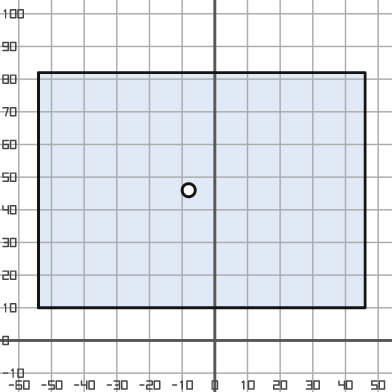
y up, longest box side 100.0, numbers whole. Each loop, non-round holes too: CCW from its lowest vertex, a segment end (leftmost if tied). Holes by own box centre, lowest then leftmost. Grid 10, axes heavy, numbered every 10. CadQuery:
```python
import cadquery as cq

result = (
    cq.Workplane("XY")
    .moveTo(-54.0, 10.0)
    .lineTo(46.0, 10.0)
    .lineTo(46.0, 82.0)
    .lineTo(-54.0, 82.0)
    .close()
    .moveTo(-8.0, 46.0)
    .circle(2.0)
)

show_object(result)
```